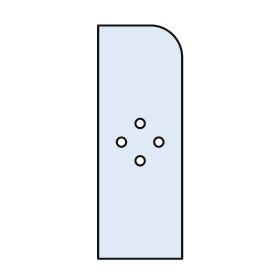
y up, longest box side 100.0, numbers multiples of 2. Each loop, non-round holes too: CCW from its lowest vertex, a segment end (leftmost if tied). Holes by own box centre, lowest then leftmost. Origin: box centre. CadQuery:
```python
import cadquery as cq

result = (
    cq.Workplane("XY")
    .moveTo(-18.0, -50.0)
    .lineTo(18.0, -50.0)
    .lineTo(18.0, 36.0)
    .threePointArc((14.0, 46.0), (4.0, 50.0))
    .lineTo(-18.0, 50.0)
    .close()
    .moveTo(0.0, -8.0)
    .circle(2.0)
    .moveTo(-8.0, 0.0)
    .circle(2.0)
    .moveTo(8.0, 0.0)
    .circle(2.0)
    .moveTo(0.0, 8.0)
    .circle(2.0)
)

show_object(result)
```